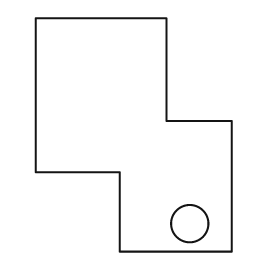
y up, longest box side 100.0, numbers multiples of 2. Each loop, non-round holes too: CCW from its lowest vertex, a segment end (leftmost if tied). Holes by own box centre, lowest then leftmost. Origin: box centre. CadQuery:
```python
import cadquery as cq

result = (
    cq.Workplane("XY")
    .moveTo(-6.0, -50.0)
    .lineTo(42.0, -50.0)
    .lineTo(42.0, 6.0)
    .lineTo(14.0, 6.0)
    .lineTo(14.0, 50.0)
    .lineTo(-42.0, 50.0)
    .lineTo(-42.0, -16.0)
    .lineTo(-6.0, -16.0)
    .close()
    .moveTo(24.0, -38.0)
    .circle(8.0)
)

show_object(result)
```